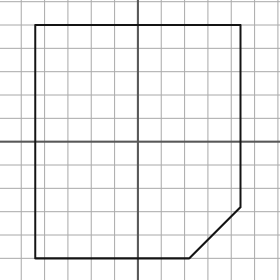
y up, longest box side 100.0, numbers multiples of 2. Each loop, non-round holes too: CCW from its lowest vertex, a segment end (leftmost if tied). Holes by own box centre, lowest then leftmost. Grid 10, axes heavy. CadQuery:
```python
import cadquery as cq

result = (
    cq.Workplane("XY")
    .moveTo(-44.0, -50.0)
    .lineTo(22.0, -50.0)
    .lineTo(44.0, -28.0)
    .lineTo(44.0, 50.0)
    .lineTo(-44.0, 50.0)
    .close()
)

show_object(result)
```